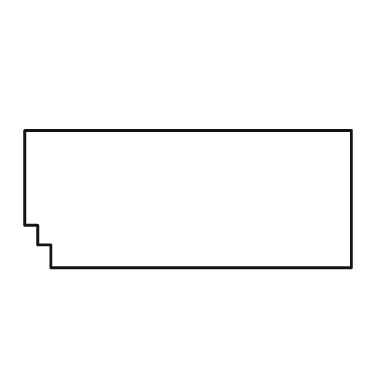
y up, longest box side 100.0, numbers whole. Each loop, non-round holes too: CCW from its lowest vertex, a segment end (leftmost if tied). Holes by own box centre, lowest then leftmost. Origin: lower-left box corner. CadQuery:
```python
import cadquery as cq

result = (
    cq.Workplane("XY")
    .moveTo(8.0, 0.0)
    .lineTo(100.0, 0.0)
    .lineTo(100.0, 42.0)
    .lineTo(0.0, 42.0)
    .lineTo(0.0, 13.0)
    .lineTo(4.0, 13.0)
    .lineTo(4.0, 7.0)
    .lineTo(8.0, 7.0)
    .close()
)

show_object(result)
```